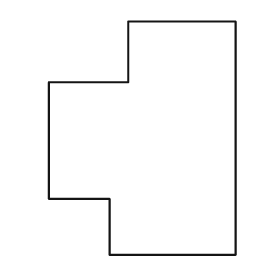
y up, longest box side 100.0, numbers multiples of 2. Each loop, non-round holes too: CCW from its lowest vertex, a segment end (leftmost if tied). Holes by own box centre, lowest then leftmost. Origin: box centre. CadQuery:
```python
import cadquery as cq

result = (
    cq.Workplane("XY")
    .moveTo(-14.0, -50.0)
    .lineTo(40.0, -50.0)
    .lineTo(40.0, 50.0)
    .lineTo(-6.0, 50.0)
    .lineTo(-6.0, 24.0)
    .lineTo(-40.0, 24.0)
    .lineTo(-40.0, -26.0)
    .lineTo(-14.0, -26.0)
    .close()
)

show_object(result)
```